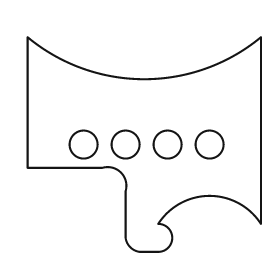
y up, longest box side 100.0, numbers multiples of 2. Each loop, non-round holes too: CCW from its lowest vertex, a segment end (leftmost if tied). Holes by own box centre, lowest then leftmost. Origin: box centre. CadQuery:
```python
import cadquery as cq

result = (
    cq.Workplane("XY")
    .moveTo(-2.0, -46.0)
    .lineTo(6.0, -46.0)
    .threePointArc((12.0, -40.0), (6.0, -34.0))
    .threePointArc((28.0, -22.0), (50.0, -34.0))
    .lineTo(50.0, 46.0)
    .threePointArc((0.0, 28.0), (-50.0, 46.0))
    .lineTo(-50.0, -10.0)
    .lineTo(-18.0, -10.0)
    .threePointArc((-10.0, -12.0), (-8.0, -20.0))
    .lineTo(-8.0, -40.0)
    .threePointArc((-6.0, -44.0), (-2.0, -46.0))
    .close()
    .moveTo(-26.0, 0.0)
    .circle(6.0)
    .moveTo(-8.0, 0.0)
    .circle(6.0)
    .moveTo(10.0, 0.0)
    .circle(6.0)
    .moveTo(28.0, 0.0)
    .circle(6.0)
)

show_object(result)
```